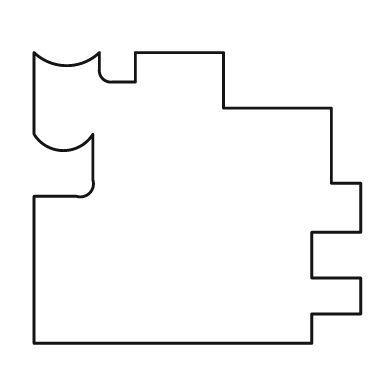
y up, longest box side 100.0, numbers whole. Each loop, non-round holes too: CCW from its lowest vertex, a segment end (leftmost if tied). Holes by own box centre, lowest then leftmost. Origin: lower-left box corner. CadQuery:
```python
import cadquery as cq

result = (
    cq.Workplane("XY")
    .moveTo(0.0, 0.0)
    .lineTo(85.0, 0.0)
    .lineTo(85.0, 9.0)
    .lineTo(100.0, 9.0)
    .lineTo(100.0, 20.0)
    .lineTo(85.0, 20.0)
    .lineTo(85.0, 34.0)
    .lineTo(100.0, 34.0)
    .lineTo(100.0, 49.0)
    .lineTo(91.0, 49.0)
    .lineTo(91.0, 72.0)
    .lineTo(58.0, 72.0)
    .lineTo(58.0, 89.0)
    .lineTo(31.0, 89.0)
    .lineTo(31.0, 80.0)
    .lineTo(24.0, 80.0)
    .threePointArc((21.0, 81.0), (20.0, 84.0))
    .lineTo(20.0, 89.0)
    .threePointArc((10.0, 85.0), (0.0, 89.0))
    .lineTo(0.0, 64.0)
    .threePointArc((9.0, 59.0), (18.0, 64.0))
    .lineTo(18.0, 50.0)
    .threePointArc((17.0, 46.0), (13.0, 45.0))
    .lineTo(0.0, 45.0)
    .close()
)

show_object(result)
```